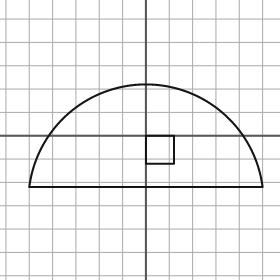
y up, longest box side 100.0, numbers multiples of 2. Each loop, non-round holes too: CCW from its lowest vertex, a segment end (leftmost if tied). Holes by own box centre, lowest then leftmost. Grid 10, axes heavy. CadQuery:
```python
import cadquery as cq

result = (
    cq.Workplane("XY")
    .moveTo(-50.0, -22.0)
    .lineTo(50.0, -22.0)
    .threePointArc((0.0, 22.0), (-50.0, -22.0))
    .close()
    .moveTo(0.0, -12.0)
    .lineTo(12.0, -12.0)
    .lineTo(12.0, 0.0)
    .lineTo(0.0, 0.0)
    .close()
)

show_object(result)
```